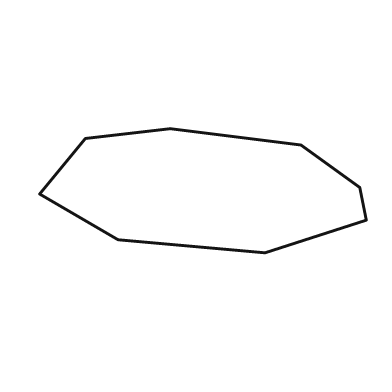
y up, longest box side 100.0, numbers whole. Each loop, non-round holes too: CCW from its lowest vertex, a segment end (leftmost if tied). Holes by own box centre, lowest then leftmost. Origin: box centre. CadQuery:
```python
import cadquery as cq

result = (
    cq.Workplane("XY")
    .moveTo(19.0, -19.0)
    .lineTo(50.0, -9.0)
    .lineTo(48.0, 1.0)
    .lineTo(30.0, 14.0)
    .lineTo(-10.0, 19.0)
    .lineTo(-36.0, 16.0)
    .lineTo(-50.0, -1.0)
    .lineTo(-26.0, -15.0)
    .close()
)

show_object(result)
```